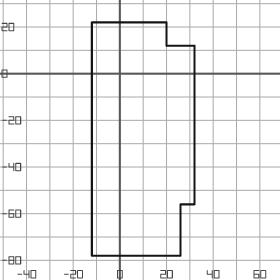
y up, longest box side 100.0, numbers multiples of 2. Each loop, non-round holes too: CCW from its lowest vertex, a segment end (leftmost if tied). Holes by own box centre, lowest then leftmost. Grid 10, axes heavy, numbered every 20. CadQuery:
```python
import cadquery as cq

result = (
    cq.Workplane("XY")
    .moveTo(-12.0, -78.0)
    .lineTo(26.0, -78.0)
    .lineTo(26.0, -56.0)
    .lineTo(32.0, -56.0)
    .lineTo(32.0, 12.0)
    .lineTo(20.0, 12.0)
    .lineTo(20.0, 22.0)
    .lineTo(-12.0, 22.0)
    .close()
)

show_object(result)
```